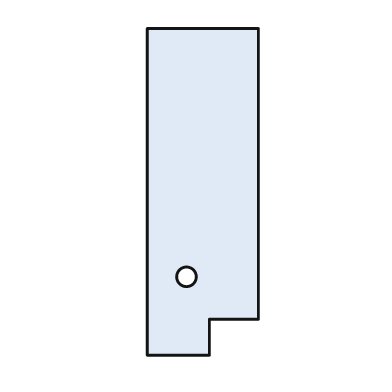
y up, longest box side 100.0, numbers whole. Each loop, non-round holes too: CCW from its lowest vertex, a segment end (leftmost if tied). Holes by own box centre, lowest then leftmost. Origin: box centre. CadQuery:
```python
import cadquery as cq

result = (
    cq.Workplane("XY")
    .moveTo(-17.0, -50.0)
    .lineTo(2.0, -50.0)
    .lineTo(2.0, -39.0)
    .lineTo(17.0, -39.0)
    .lineTo(17.0, 50.0)
    .lineTo(-17.0, 50.0)
    .close()
    .moveTo(-5.0, -26.0)
    .circle(3.0)
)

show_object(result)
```